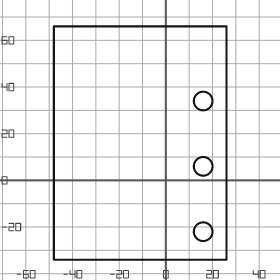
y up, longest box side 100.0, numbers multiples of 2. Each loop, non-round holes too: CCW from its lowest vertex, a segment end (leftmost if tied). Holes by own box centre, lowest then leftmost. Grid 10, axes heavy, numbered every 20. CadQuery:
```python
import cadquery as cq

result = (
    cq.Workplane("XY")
    .moveTo(-48.0, -34.0)
    .lineTo(26.0, -34.0)
    .lineTo(26.0, 66.0)
    .lineTo(-48.0, 66.0)
    .close()
    .moveTo(16.0, -22.0)
    .circle(4.0)
    .moveTo(16.0, 6.0)
    .circle(4.0)
    .moveTo(16.0, 34.0)
    .circle(4.0)
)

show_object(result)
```